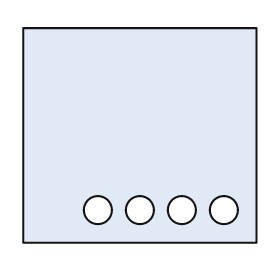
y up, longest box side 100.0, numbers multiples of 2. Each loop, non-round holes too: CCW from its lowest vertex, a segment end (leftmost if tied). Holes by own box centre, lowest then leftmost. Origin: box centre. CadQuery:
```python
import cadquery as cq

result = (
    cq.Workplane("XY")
    .moveTo(-50.0, -46.0)
    .lineTo(50.0, -46.0)
    .lineTo(50.0, 46.0)
    .lineTo(-50.0, 46.0)
    .close()
    .moveTo(-18.0, -32.0)
    .circle(6.0)
    .moveTo(0.0, -32.0)
    .circle(6.0)
    .moveTo(18.0, -32.0)
    .circle(6.0)
    .moveTo(36.0, -32.0)
    .circle(6.0)
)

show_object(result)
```